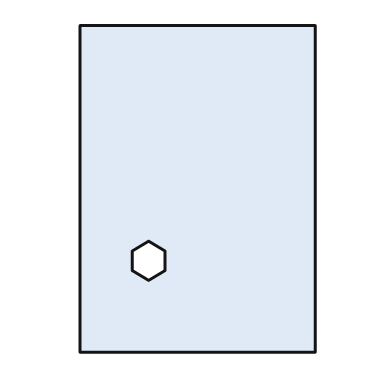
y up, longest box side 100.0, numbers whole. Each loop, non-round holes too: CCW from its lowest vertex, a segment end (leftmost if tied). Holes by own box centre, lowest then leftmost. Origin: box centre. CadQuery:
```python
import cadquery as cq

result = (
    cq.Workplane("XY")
    .moveTo(-36.0, -50.0)
    .lineTo(36.0, -50.0)
    .lineTo(36.0, 50.0)
    .lineTo(-36.0, 50.0)
    .close()
    .moveTo(-15.0, -28.0)
    .lineTo(-10.0, -25.0)
    .lineTo(-10.0, -19.0)
    .lineTo(-15.0, -16.0)
    .lineTo(-20.0, -19.0)
    .lineTo(-20.0, -25.0)
    .close()
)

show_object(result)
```